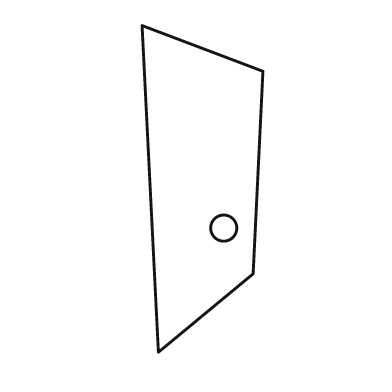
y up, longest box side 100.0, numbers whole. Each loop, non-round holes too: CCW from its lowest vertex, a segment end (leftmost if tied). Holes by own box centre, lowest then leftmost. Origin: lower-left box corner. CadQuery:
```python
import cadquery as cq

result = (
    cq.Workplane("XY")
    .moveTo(5.0, 0.0)
    .lineTo(34.0, 24.0)
    .lineTo(37.0, 86.0)
    .lineTo(0.0, 100.0)
    .close()
    .moveTo(25.0, 38.0)
    .circle(4.0)
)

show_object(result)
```